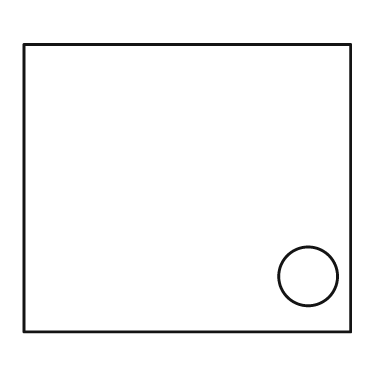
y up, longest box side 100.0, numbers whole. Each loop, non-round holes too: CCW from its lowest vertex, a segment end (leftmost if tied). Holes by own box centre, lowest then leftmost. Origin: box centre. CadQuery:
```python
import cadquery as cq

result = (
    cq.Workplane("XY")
    .moveTo(-50.0, -44.0)
    .lineTo(50.0, -44.0)
    .lineTo(50.0, 44.0)
    .lineTo(-50.0, 44.0)
    .close()
    .moveTo(37.0, -27.0)
    .circle(9.0)
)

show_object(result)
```